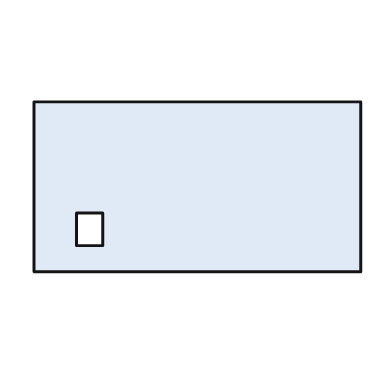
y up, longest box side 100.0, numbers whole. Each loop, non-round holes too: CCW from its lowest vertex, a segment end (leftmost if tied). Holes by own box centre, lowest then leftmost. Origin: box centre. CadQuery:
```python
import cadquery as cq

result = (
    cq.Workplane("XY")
    .moveTo(-50.0, -26.0)
    .lineTo(50.0, -26.0)
    .lineTo(50.0, 26.0)
    .lineTo(-50.0, 26.0)
    .close()
    .moveTo(-37.0, -18.0)
    .lineTo(-29.0, -18.0)
    .lineTo(-29.0, -8.0)
    .lineTo(-37.0, -8.0)
    .close()
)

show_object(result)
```